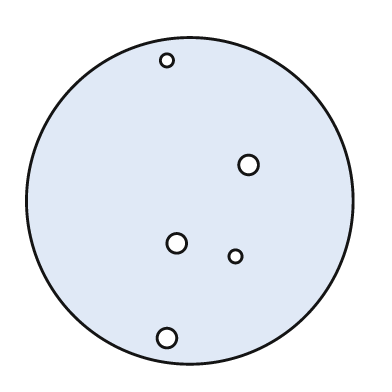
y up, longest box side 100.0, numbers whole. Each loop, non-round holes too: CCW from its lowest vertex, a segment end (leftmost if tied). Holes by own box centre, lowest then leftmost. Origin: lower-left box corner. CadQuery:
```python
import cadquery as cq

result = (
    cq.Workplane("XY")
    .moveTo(50.0, 50.0)
    .circle(50.0)
    .moveTo(43.0, 8.0)
    .circle(3.0)
    .moveTo(64.0, 33.0)
    .circle(2.0)
    .moveTo(46.0, 37.0)
    .circle(3.0)
    .moveTo(68.0, 61.0)
    .circle(3.0)
    .moveTo(43.0, 93.0)
    .circle(2.0)
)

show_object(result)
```